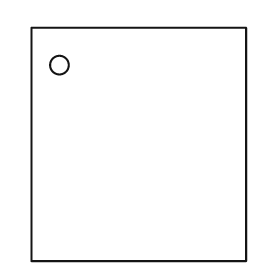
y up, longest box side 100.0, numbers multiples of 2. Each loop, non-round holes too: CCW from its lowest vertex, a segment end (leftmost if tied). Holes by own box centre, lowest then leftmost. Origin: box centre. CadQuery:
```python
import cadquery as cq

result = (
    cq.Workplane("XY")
    .moveTo(-46.0, -50.0)
    .lineTo(46.0, -50.0)
    .lineTo(46.0, 50.0)
    .lineTo(-46.0, 50.0)
    .close()
    .moveTo(-34.0, 34.0)
    .circle(4.0)
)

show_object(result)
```